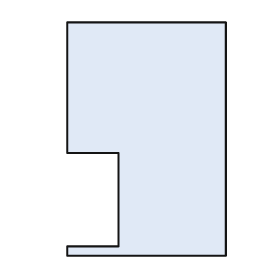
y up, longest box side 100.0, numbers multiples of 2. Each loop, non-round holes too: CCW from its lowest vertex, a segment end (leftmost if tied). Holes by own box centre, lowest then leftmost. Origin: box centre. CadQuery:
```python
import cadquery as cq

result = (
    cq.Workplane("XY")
    .moveTo(-34.0, -50.0)
    .lineTo(34.0, -50.0)
    .lineTo(34.0, 50.0)
    .lineTo(-34.0, 50.0)
    .lineTo(-34.0, -6.0)
    .lineTo(-12.0, -6.0)
    .lineTo(-12.0, -46.0)
    .lineTo(-34.0, -46.0)
    .close()
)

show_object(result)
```